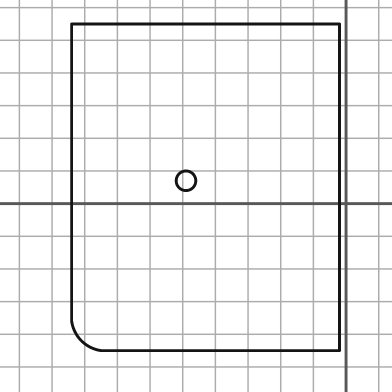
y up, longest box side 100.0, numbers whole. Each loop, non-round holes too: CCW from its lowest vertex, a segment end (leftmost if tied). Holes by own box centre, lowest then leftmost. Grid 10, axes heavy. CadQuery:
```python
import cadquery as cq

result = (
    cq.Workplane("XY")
    .moveTo(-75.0, -45.0)
    .lineTo(-2.0, -45.0)
    .lineTo(-2.0, 55.0)
    .lineTo(-84.0, 55.0)
    .lineTo(-84.0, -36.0)
    .threePointArc((-81.0, -42.0), (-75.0, -45.0))
    .close()
    .moveTo(-49.0, 7.0)
    .circle(3.0)
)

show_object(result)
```